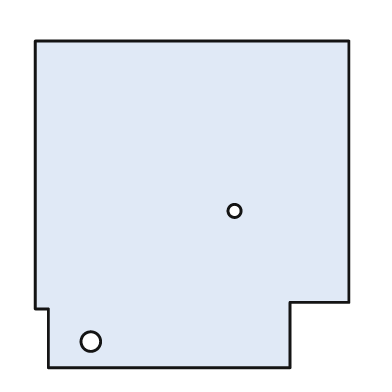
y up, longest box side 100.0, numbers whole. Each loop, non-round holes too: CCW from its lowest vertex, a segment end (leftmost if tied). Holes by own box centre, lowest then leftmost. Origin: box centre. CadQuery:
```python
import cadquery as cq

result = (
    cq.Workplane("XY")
    .moveTo(-44.0, -50.0)
    .lineTo(30.0, -50.0)
    .lineTo(30.0, -30.0)
    .lineTo(48.0, -30.0)
    .lineTo(48.0, 50.0)
    .lineTo(-48.0, 50.0)
    .lineTo(-48.0, -32.0)
    .lineTo(-44.0, -32.0)
    .close()
    .moveTo(-31.0, -42.0)
    .circle(3.0)
    .moveTo(13.0, -2.0)
    .circle(2.0)
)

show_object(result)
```